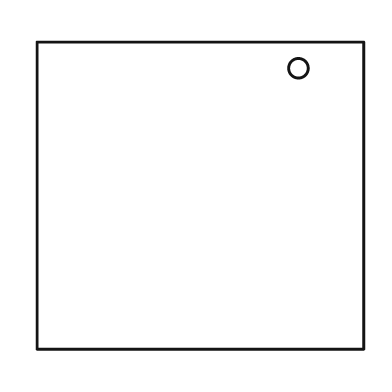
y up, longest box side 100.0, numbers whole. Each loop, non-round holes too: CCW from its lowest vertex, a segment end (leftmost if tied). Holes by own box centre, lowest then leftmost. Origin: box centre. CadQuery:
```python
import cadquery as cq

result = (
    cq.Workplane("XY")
    .moveTo(-50.0, -47.0)
    .lineTo(50.0, -47.0)
    .lineTo(50.0, 47.0)
    .lineTo(-50.0, 47.0)
    .close()
    .moveTo(30.0, 39.0)
    .circle(3.0)
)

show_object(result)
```